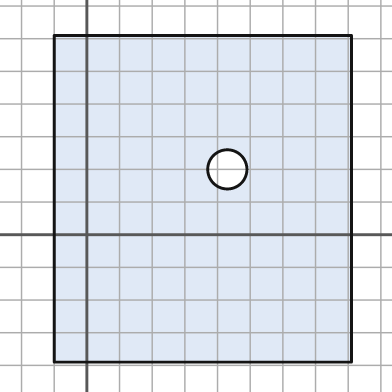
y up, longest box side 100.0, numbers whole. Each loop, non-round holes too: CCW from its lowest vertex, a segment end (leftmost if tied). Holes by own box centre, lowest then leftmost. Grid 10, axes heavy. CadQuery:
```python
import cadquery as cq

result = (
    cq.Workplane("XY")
    .moveTo(-10.0, -39.0)
    .lineTo(81.0, -39.0)
    .lineTo(81.0, 61.0)
    .lineTo(-10.0, 61.0)
    .close()
    .moveTo(43.0, 20.0)
    .circle(6.0)
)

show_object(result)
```